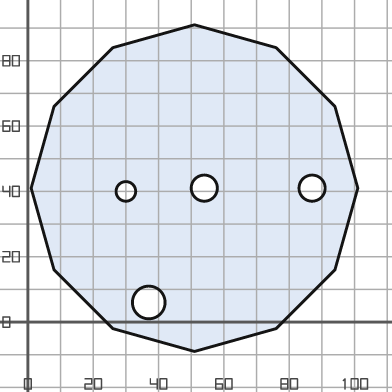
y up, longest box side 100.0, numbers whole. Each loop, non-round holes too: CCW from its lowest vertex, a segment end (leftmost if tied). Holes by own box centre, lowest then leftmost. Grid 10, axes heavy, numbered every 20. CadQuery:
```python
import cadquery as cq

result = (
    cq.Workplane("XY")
    .moveTo(51.0, -9.0)
    .lineTo(76.0, -2.0)
    .lineTo(94.0, 16.0)
    .lineTo(101.0, 41.0)
    .lineTo(94.0, 66.0)
    .lineTo(76.0, 84.0)
    .lineTo(51.0, 91.0)
    .lineTo(26.0, 84.0)
    .lineTo(8.0, 66.0)
    .lineTo(1.0, 41.0)
    .lineTo(8.0, 16.0)
    .lineTo(26.0, -2.0)
    .close()
    .moveTo(37.0, 6.0)
    .circle(5.0)
    .moveTo(30.0, 40.0)
    .circle(3.0)
    .moveTo(54.0, 41.0)
    .circle(4.0)
    .moveTo(87.0, 41.0)
    .circle(4.0)
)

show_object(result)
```